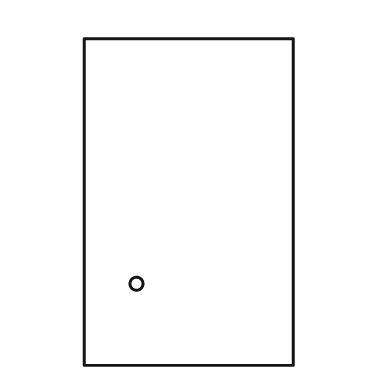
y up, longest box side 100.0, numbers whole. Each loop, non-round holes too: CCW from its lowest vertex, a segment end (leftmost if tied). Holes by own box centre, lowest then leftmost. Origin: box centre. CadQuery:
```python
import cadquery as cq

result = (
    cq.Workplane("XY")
    .moveTo(-32.0, -50.0)
    .lineTo(32.0, -50.0)
    .lineTo(32.0, 50.0)
    .lineTo(-32.0, 50.0)
    .close()
    .moveTo(-16.0, -25.0)
    .circle(2.0)
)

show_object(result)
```